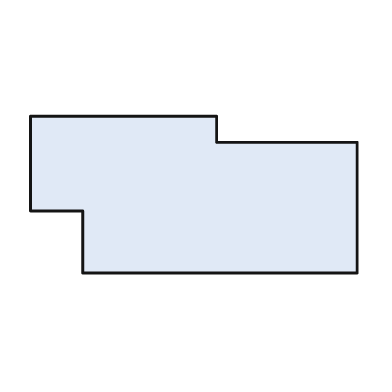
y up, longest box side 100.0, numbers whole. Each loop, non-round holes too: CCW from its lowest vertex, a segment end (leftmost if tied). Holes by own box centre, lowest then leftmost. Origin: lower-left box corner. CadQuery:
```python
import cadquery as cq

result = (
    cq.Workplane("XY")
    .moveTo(16.0, 0.0)
    .lineTo(100.0, 0.0)
    .lineTo(100.0, 40.0)
    .lineTo(57.0, 40.0)
    .lineTo(57.0, 48.0)
    .lineTo(0.0, 48.0)
    .lineTo(0.0, 19.0)
    .lineTo(16.0, 19.0)
    .close()
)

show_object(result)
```